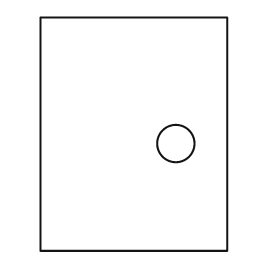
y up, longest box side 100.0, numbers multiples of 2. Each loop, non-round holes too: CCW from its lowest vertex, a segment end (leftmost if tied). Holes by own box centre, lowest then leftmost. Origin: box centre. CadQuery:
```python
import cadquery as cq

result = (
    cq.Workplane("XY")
    .moveTo(-40.0, -50.0)
    .lineTo(40.0, -50.0)
    .lineTo(40.0, 50.0)
    .lineTo(-40.0, 50.0)
    .close()
    .moveTo(18.0, -4.0)
    .circle(8.0)
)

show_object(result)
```